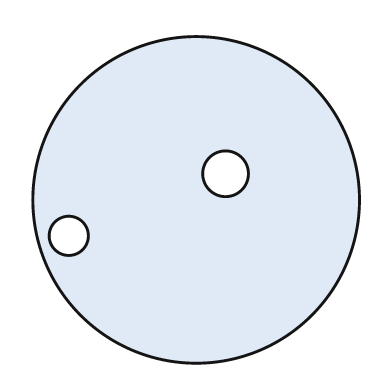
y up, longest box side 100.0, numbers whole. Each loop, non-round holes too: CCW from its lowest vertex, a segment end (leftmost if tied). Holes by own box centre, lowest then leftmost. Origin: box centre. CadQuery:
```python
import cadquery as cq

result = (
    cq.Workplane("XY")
    .moveTo(0.0, 0.0)
    .circle(50.0)
    .moveTo(-39.0, -11.0)
    .circle(6.0)
    .moveTo(9.0, 8.0)
    .circle(7.0)
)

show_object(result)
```